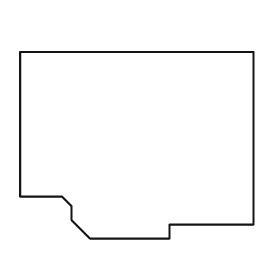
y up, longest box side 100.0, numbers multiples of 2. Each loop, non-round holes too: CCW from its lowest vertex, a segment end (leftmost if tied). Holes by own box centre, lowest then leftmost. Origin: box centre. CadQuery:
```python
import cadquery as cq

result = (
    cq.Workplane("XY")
    .moveTo(-20.0, -40.0)
    .lineTo(14.0, -40.0)
    .lineTo(14.0, -34.0)
    .lineTo(50.0, -34.0)
    .lineTo(50.0, 40.0)
    .lineTo(-50.0, 40.0)
    .lineTo(-50.0, -22.0)
    .lineTo(-32.0, -22.0)
    .lineTo(-28.0, -26.0)
    .lineTo(-28.0, -32.0)
    .close()
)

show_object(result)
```